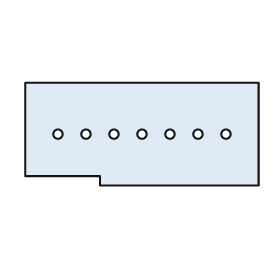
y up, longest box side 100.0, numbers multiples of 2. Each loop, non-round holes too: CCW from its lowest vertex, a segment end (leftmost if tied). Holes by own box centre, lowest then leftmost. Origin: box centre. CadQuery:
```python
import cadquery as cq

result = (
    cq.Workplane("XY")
    .moveTo(-18.0, -22.0)
    .lineTo(50.0, -22.0)
    .lineTo(50.0, 22.0)
    .lineTo(-50.0, 22.0)
    .lineTo(-50.0, -18.0)
    .lineTo(-18.0, -18.0)
    .close()
    .moveTo(-36.0, 0.0)
    .circle(2.0)
    .moveTo(-24.0, 0.0)
    .circle(2.0)
    .moveTo(-12.0, 0.0)
    .circle(2.0)
    .moveTo(0.0, 0.0)
    .circle(2.0)
    .moveTo(12.0, 0.0)
    .circle(2.0)
    .moveTo(24.0, 0.0)
    .circle(2.0)
    .moveTo(36.0, 0.0)
    .circle(2.0)
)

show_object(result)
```